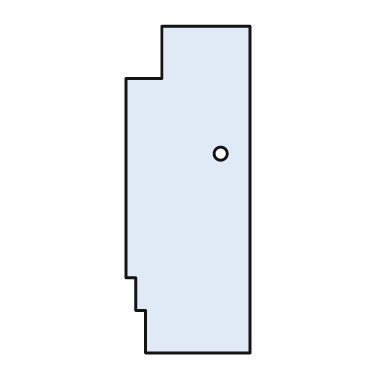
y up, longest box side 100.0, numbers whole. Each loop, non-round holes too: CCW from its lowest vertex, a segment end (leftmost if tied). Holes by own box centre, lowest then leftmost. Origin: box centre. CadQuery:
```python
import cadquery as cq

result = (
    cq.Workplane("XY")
    .moveTo(-13.0, -50.0)
    .lineTo(19.0, -50.0)
    .lineTo(19.0, 50.0)
    .lineTo(-8.0, 50.0)
    .lineTo(-8.0, 34.0)
    .lineTo(-19.0, 34.0)
    .lineTo(-19.0, -27.0)
    .lineTo(-16.0, -27.0)
    .lineTo(-16.0, -37.0)
    .lineTo(-13.0, -37.0)
    .close()
    .moveTo(10.0, 11.0)
    .circle(2.0)
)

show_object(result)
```